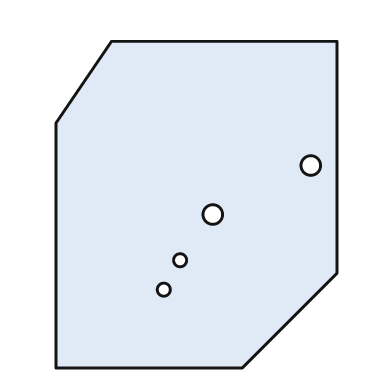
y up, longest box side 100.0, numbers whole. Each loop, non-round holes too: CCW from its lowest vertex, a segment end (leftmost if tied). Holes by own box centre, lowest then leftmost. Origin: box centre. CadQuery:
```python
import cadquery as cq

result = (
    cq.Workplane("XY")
    .moveTo(-43.0, -50.0)
    .lineTo(14.0, -50.0)
    .lineTo(43.0, -21.0)
    .lineTo(43.0, 50.0)
    .lineTo(-26.0, 50.0)
    .lineTo(-43.0, 25.0)
    .close()
    .moveTo(-10.0, -26.0)
    .circle(2.0)
    .moveTo(-5.0, -17.0)
    .circle(2.0)
    .moveTo(5.0, -3.0)
    .circle(3.0)
    .moveTo(35.0, 12.0)
    .circle(3.0)
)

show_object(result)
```